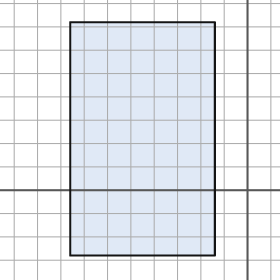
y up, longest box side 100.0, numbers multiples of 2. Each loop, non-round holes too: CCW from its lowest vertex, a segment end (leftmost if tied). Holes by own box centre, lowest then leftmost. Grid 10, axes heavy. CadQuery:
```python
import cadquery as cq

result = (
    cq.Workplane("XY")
    .moveTo(-76.0, -28.0)
    .lineTo(-14.0, -28.0)
    .lineTo(-14.0, 72.0)
    .lineTo(-76.0, 72.0)
    .close()
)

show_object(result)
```